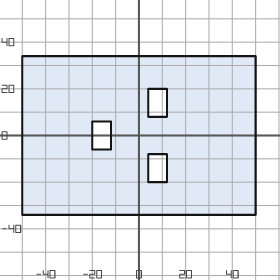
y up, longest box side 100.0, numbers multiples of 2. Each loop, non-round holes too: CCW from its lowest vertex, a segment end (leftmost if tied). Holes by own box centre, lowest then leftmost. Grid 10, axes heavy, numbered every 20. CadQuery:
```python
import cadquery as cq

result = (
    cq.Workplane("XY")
    .moveTo(-50.0, -34.0)
    .lineTo(50.0, -34.0)
    .lineTo(50.0, 34.0)
    .lineTo(-50.0, 34.0)
    .close()
    .moveTo(4.0, -20.0)
    .lineTo(12.0, -20.0)
    .lineTo(12.0, -8.0)
    .lineTo(4.0, -8.0)
    .close()
    .moveTo(-20.0, -6.0)
    .lineTo(-12.0, -6.0)
    .lineTo(-12.0, 6.0)
    .lineTo(-20.0, 6.0)
    .close()
    .moveTo(4.0, 8.0)
    .lineTo(12.0, 8.0)
    .lineTo(12.0, 20.0)
    .lineTo(4.0, 20.0)
    .close()
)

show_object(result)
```